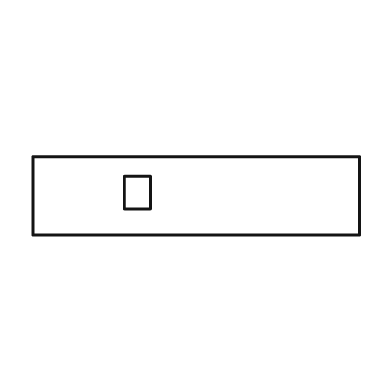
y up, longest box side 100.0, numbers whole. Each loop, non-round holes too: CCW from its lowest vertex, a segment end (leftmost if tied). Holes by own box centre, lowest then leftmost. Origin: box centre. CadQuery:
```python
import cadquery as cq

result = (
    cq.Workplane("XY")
    .moveTo(-50.0, -12.0)
    .lineTo(50.0, -12.0)
    .lineTo(50.0, 12.0)
    .lineTo(-50.0, 12.0)
    .close()
    .moveTo(-22.0, -4.0)
    .lineTo(-14.0, -4.0)
    .lineTo(-14.0, 6.0)
    .lineTo(-22.0, 6.0)
    .close()
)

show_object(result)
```